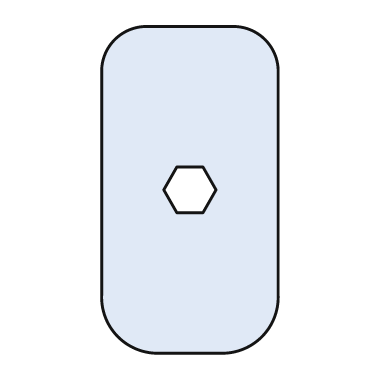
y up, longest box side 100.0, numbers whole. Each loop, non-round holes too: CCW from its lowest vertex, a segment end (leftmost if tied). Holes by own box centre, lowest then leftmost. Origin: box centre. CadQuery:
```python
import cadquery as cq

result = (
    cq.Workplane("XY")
    .moveTo(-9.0, -50.0)
    .lineTo(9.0, -50.0)
    .threePointArc((22.0, -45.0), (27.0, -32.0))
    .lineTo(27.0, 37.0)
    .threePointArc((23.0, 46.0), (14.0, 50.0))
    .lineTo(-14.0, 50.0)
    .threePointArc((-23.0, 46.0), (-27.0, 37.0))
    .lineTo(-27.0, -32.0)
    .threePointArc((-22.0, -45.0), (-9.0, -50.0))
    .close()
    .moveTo(-4.0, -7.0)
    .lineTo(4.0, -7.0)
    .lineTo(8.0, 0.0)
    .lineTo(4.0, 7.0)
    .lineTo(-4.0, 7.0)
    .lineTo(-8.0, 0.0)
    .close()
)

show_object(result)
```